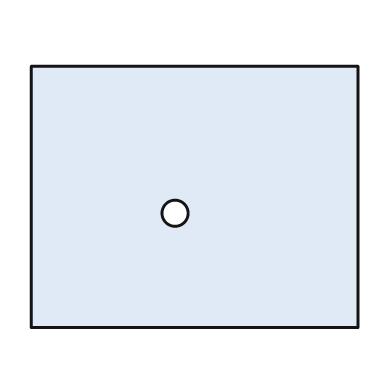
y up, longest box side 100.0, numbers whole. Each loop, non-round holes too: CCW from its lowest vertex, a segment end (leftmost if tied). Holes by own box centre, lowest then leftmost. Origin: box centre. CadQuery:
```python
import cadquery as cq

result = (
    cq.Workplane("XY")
    .moveTo(-50.0, -40.0)
    .lineTo(50.0, -40.0)
    .lineTo(50.0, 40.0)
    .lineTo(-50.0, 40.0)
    .close()
    .moveTo(-6.0, -5.0)
    .circle(4.0)
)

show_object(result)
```